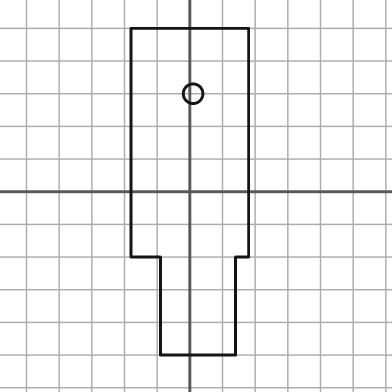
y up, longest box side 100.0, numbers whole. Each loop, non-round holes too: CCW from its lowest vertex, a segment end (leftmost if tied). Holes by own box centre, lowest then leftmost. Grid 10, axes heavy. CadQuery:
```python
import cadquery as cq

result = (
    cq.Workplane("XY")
    .moveTo(-9.0, -50.0)
    .lineTo(14.0, -50.0)
    .lineTo(14.0, -20.0)
    .lineTo(18.0, -20.0)
    .lineTo(18.0, 50.0)
    .lineTo(-18.0, 50.0)
    .lineTo(-18.0, -20.0)
    .lineTo(-9.0, -20.0)
    .close()
    .moveTo(1.0, 30.0)
    .circle(3.0)
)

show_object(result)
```